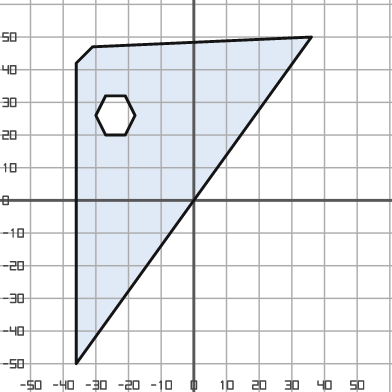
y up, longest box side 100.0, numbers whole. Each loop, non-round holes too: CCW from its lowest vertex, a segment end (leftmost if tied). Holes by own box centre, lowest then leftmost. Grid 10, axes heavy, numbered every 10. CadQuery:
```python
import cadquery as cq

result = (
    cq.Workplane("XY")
    .moveTo(-36.0, -50.0)
    .lineTo(36.0, 50.0)
    .lineTo(-31.0, 47.0)
    .lineTo(-36.0, 42.0)
    .close()
    .moveTo(-27.0, 20.0)
    .lineTo(-21.0, 20.0)
    .lineTo(-18.0, 26.0)
    .lineTo(-21.0, 32.0)
    .lineTo(-27.0, 32.0)
    .lineTo(-30.0, 26.0)
    .close()
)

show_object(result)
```